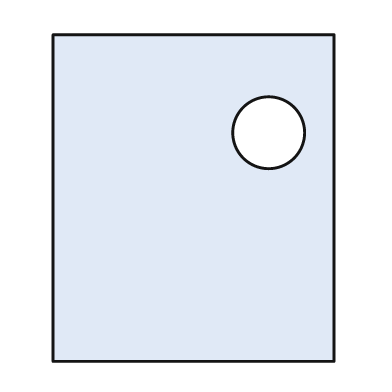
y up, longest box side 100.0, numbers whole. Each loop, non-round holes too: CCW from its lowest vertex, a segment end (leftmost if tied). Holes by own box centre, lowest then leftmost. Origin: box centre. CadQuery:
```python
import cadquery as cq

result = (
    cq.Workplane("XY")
    .moveTo(-43.0, -50.0)
    .lineTo(43.0, -50.0)
    .lineTo(43.0, 50.0)
    .lineTo(-43.0, 50.0)
    .close()
    .moveTo(23.0, 20.0)
    .circle(11.0)
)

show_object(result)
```